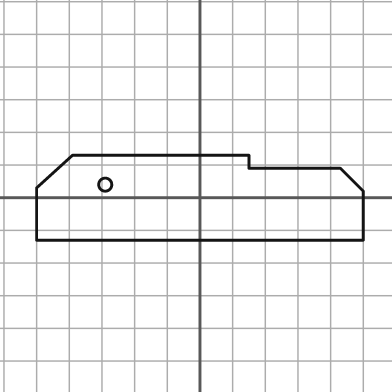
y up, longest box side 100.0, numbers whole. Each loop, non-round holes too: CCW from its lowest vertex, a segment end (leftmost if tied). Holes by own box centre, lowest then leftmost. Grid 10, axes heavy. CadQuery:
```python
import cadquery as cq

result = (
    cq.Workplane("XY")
    .moveTo(-50.0, -13.0)
    .lineTo(50.0, -13.0)
    .lineTo(50.0, 2.0)
    .lineTo(43.0, 9.0)
    .lineTo(15.0, 9.0)
    .lineTo(15.0, 13.0)
    .lineTo(-39.0, 13.0)
    .lineTo(-50.0, 3.0)
    .close()
    .moveTo(-29.0, 4.0)
    .circle(2.0)
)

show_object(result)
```